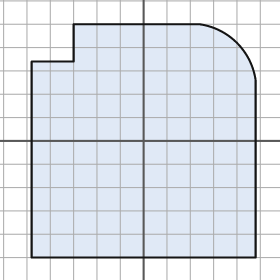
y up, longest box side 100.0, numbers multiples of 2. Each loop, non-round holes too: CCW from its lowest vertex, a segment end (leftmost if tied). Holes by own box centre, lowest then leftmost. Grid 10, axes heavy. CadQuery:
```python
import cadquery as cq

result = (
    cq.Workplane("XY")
    .moveTo(-48.0, -50.0)
    .lineTo(48.0, -50.0)
    .lineTo(48.0, 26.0)
    .threePointArc((40.0, 42.0), (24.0, 50.0))
    .lineTo(-30.0, 50.0)
    .lineTo(-30.0, 34.0)
    .lineTo(-48.0, 34.0)
    .close()
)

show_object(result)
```